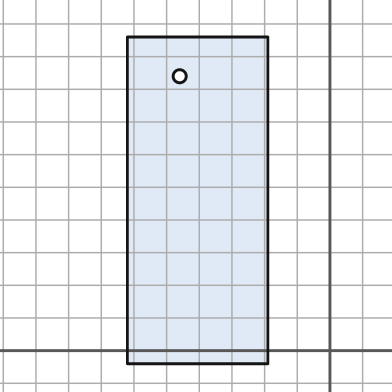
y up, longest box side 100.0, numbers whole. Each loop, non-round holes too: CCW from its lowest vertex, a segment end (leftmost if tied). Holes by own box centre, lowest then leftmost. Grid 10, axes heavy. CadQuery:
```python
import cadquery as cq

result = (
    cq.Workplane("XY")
    .moveTo(-62.0, -4.0)
    .lineTo(-19.0, -4.0)
    .lineTo(-19.0, 96.0)
    .lineTo(-62.0, 96.0)
    .close()
    .moveTo(-46.0, 84.0)
    .circle(2.0)
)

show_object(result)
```